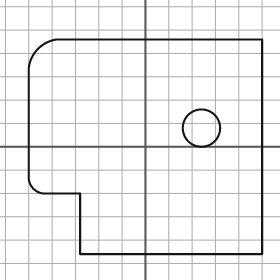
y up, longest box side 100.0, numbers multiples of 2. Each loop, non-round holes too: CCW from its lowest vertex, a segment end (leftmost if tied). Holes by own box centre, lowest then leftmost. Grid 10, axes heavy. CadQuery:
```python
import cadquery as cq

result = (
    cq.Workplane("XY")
    .moveTo(-28.0, -46.0)
    .lineTo(50.0, -46.0)
    .lineTo(50.0, 46.0)
    .lineTo(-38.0, 46.0)
    .threePointArc((-46.0, 42.0), (-50.0, 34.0))
    .lineTo(-50.0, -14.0)
    .threePointArc((-48.0, -18.0), (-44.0, -20.0))
    .lineTo(-28.0, -20.0)
    .close()
    .moveTo(24.0, 8.0)
    .circle(8.0)
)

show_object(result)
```